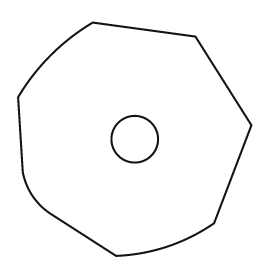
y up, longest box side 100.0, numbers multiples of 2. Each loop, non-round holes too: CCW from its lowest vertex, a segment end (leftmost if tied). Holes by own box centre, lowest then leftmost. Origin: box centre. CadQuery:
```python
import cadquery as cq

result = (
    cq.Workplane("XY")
    .moveTo(-8.0, -50.0)
    .threePointArc((14.0, -46.0), (34.0, -36.0))
    .lineTo(50.0, 6.0)
    .lineTo(26.0, 44.0)
    .lineTo(-18.0, 50.0)
    .threePointArc((-36.0, 36.0), (-50.0, 18.0))
    .lineTo(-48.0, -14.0)
    .threePointArc((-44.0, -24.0), (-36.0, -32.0))
    .close()
    .moveTo(0.0, 0.0)
    .circle(10.0)
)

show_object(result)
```